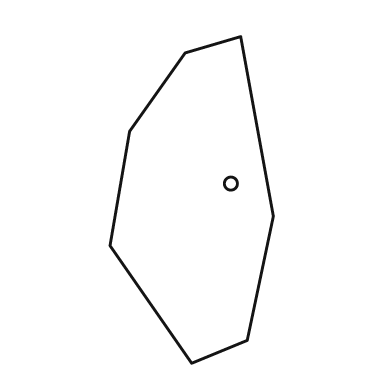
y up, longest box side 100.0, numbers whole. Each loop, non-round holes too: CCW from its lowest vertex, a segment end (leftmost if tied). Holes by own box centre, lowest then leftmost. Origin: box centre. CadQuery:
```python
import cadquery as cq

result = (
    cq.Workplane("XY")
    .moveTo(0.0, -50.0)
    .lineTo(17.0, -43.0)
    .lineTo(25.0, -5.0)
    .lineTo(15.0, 50.0)
    .lineTo(-2.0, 45.0)
    .lineTo(-19.0, 21.0)
    .lineTo(-25.0, -14.0)
    .close()
    .moveTo(12.0, 5.0)
    .circle(2.0)
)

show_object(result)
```